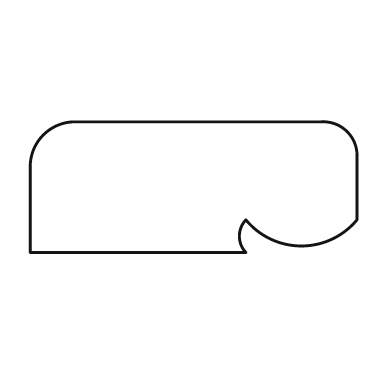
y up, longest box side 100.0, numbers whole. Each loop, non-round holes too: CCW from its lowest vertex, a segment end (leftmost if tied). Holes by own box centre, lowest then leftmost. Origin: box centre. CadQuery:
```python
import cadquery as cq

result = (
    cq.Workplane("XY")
    .moveTo(-50.0, -20.0)
    .lineTo(16.0, -20.0)
    .threePointArc((14.0, -15.0), (16.0, -10.0))
    .threePointArc((33.0, -18.0), (50.0, -10.0))
    .lineTo(50.0, 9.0)
    .threePointArc((47.0, 17.0), (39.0, 20.0))
    .lineTo(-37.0, 20.0)
    .threePointArc((-46.0, 16.0), (-50.0, 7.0))
    .close()
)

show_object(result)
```